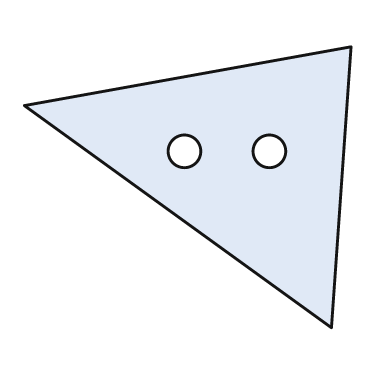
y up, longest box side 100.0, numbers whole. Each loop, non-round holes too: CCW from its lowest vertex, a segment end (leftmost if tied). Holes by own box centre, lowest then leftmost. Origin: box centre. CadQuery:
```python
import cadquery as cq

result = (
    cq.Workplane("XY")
    .moveTo(44.0, -43.0)
    .lineTo(50.0, 43.0)
    .lineTo(-50.0, 25.0)
    .close()
    .moveTo(-1.0, 11.0)
    .circle(5.0)
    .moveTo(25.0, 11.0)
    .circle(5.0)
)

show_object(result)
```